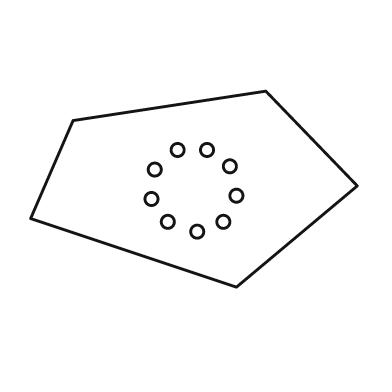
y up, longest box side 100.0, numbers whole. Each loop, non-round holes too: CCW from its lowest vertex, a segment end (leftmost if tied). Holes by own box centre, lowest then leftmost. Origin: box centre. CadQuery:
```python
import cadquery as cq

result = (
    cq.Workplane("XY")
    .moveTo(13.0, -30.0)
    .lineTo(50.0, 1.0)
    .lineTo(22.0, 30.0)
    .lineTo(-37.0, 21.0)
    .lineTo(-50.0, -9.0)
    .close()
    .moveTo(1.0, -13.0)
    .circle(2.0)
    .moveTo(-8.0, -10.0)
    .circle(2.0)
    .moveTo(9.0, -10.0)
    .circle(2.0)
    .moveTo(-13.0, -3.0)
    .circle(2.0)
    .moveTo(13.0, -2.0)
    .circle(2.0)
    .moveTo(-12.0, 6.0)
    .circle(2.0)
    .moveTo(11.0, 7.0)
    .circle(2.0)
    .moveTo(-5.0, 12.0)
    .circle(2.0)
    .moveTo(4.0, 12.0)
    .circle(2.0)
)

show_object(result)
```